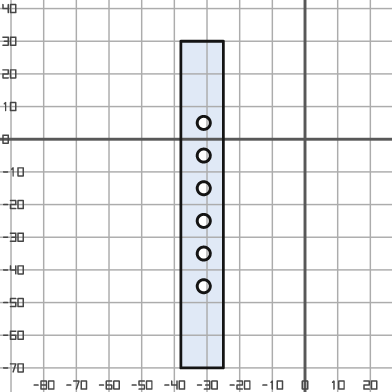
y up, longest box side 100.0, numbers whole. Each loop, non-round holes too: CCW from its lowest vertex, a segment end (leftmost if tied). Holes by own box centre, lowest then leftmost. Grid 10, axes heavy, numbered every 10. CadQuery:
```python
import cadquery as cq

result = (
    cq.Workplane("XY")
    .moveTo(-38.0, -70.0)
    .lineTo(-25.0, -70.0)
    .lineTo(-25.0, 30.0)
    .lineTo(-38.0, 30.0)
    .close()
    .moveTo(-31.0, -45.0)
    .circle(2.0)
    .moveTo(-31.0, -35.0)
    .circle(2.0)
    .moveTo(-31.0, -25.0)
    .circle(2.0)
    .moveTo(-31.0, -15.0)
    .circle(2.0)
    .moveTo(-31.0, -5.0)
    .circle(2.0)
    .moveTo(-31.0, 5.0)
    .circle(2.0)
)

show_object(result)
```